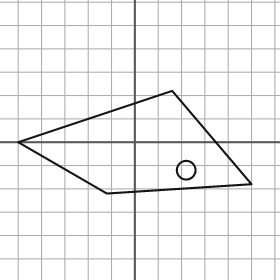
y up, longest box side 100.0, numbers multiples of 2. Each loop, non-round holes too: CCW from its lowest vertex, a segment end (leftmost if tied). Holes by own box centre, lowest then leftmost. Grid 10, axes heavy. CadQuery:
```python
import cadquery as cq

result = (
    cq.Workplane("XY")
    .moveTo(-12.0, -22.0)
    .lineTo(50.0, -18.0)
    .lineTo(16.0, 22.0)
    .lineTo(-50.0, 0.0)
    .close()
    .moveTo(22.0, -12.0)
    .circle(4.0)
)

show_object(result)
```